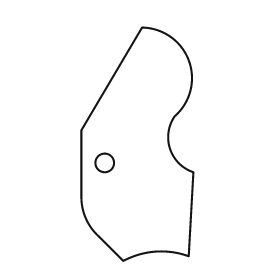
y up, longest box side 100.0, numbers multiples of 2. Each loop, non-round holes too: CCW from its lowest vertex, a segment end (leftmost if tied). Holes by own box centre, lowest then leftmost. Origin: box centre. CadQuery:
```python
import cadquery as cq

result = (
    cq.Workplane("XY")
    .moveTo(-6.0, -50.0)
    .threePointArc((8.0, -46.0), (22.0, -48.0))
    .lineTo(24.0, -12.0)
    .threePointArc((14.0, -2.0), (16.0, 12.0))
    .threePointArc((22.0, 36.0), (2.0, 50.0))
    .lineTo(-24.0, 6.0)
    .lineTo(-24.0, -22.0)
    .threePointArc((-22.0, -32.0), (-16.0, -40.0))
    .close()
    .moveTo(-14.0, -8.0)
    .circle(4.0)
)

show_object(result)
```